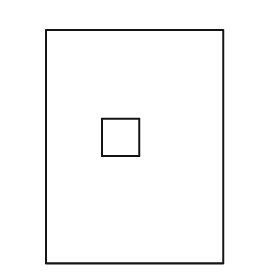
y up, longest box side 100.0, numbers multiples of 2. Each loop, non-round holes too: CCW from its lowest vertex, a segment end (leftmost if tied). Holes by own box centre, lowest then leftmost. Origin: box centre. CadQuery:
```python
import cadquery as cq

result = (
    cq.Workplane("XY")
    .moveTo(-38.0, -50.0)
    .lineTo(38.0, -50.0)
    .lineTo(38.0, 50.0)
    .lineTo(-38.0, 50.0)
    .close()
    .moveTo(-14.0, -4.0)
    .lineTo(2.0, -4.0)
    .lineTo(2.0, 12.0)
    .lineTo(-14.0, 12.0)
    .close()
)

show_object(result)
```